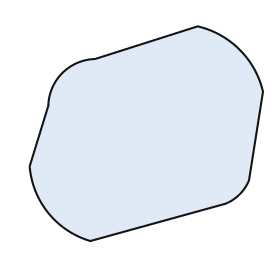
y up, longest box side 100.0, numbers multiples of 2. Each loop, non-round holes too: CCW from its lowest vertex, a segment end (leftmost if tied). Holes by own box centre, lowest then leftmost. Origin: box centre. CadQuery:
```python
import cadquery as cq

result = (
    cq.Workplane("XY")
    .moveTo(-24.0, -46.0)
    .lineTo(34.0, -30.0)
    .threePointArc((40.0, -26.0), (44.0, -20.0))
    .lineTo(50.0, 18.0)
    .threePointArc((40.0, 36.0), (22.0, 46.0))
    .lineTo(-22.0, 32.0)
    .threePointArc((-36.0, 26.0), (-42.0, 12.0))
    .lineTo(-50.0, -14.0)
    .threePointArc((-42.0, -34.0), (-24.0, -46.0))
    .close()
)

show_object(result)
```